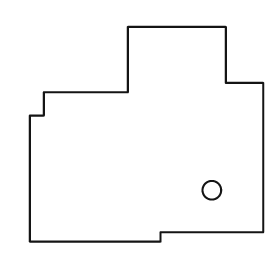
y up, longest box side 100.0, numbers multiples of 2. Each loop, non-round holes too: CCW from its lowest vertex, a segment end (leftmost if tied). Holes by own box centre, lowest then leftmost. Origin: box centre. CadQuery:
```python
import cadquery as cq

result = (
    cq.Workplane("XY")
    .moveTo(-50.0, -46.0)
    .lineTo(6.0, -46.0)
    .lineTo(6.0, -42.0)
    .lineTo(50.0, -42.0)
    .lineTo(50.0, 22.0)
    .lineTo(34.0, 22.0)
    .lineTo(34.0, 46.0)
    .lineTo(-8.0, 46.0)
    .lineTo(-8.0, 18.0)
    .lineTo(-44.0, 18.0)
    .lineTo(-44.0, 8.0)
    .lineTo(-50.0, 8.0)
    .close()
    .moveTo(28.0, -24.0)
    .circle(4.0)
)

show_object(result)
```